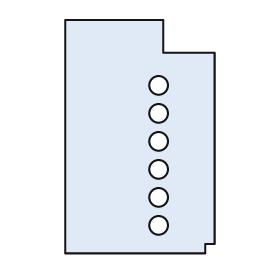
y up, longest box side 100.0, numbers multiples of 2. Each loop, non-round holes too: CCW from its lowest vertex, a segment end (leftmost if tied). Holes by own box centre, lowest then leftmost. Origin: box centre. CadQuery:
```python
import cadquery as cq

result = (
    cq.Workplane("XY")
    .moveTo(-32.0, -50.0)
    .lineTo(28.0, -50.0)
    .lineTo(28.0, -46.0)
    .lineTo(32.0, -46.0)
    .lineTo(32.0, 36.0)
    .lineTo(10.0, 36.0)
    .lineTo(10.0, 50.0)
    .lineTo(-32.0, 50.0)
    .close()
    .moveTo(8.0, -38.0)
    .circle(4.0)
    .moveTo(8.0, -26.0)
    .circle(4.0)
    .moveTo(8.0, -14.0)
    .circle(4.0)
    .moveTo(8.0, -2.0)
    .circle(4.0)
    .moveTo(8.0, 10.0)
    .circle(4.0)
    .moveTo(8.0, 22.0)
    .circle(4.0)
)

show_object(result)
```